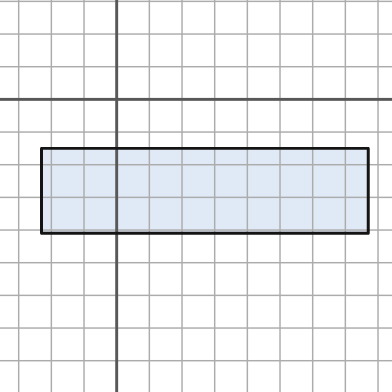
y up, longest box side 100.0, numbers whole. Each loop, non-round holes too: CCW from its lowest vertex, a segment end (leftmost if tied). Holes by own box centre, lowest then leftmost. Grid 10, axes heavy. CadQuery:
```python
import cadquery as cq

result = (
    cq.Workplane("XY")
    .moveTo(-23.0, -41.0)
    .lineTo(77.0, -41.0)
    .lineTo(77.0, -15.0)
    .lineTo(-23.0, -15.0)
    .close()
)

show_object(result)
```